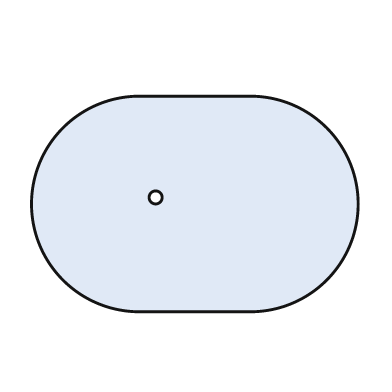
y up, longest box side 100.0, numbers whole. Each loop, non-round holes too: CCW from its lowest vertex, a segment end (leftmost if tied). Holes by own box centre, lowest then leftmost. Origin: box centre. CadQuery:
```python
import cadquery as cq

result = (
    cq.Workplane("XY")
    .moveTo(-17.0, -33.0)
    .lineTo(17.0, -33.0)
    .threePointArc((50.0, 0.0), (17.0, 33.0))
    .lineTo(-17.0, 33.0)
    .threePointArc((-50.0, 0.0), (-17.0, -33.0))
    .close()
    .moveTo(-12.0, 2.0)
    .circle(2.0)
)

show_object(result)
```